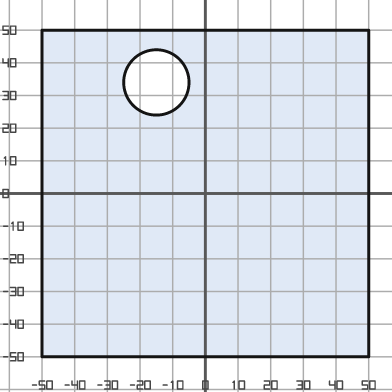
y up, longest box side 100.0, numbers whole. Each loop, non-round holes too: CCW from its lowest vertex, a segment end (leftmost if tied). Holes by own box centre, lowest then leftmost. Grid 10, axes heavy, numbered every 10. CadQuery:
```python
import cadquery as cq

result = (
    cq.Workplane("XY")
    .moveTo(-50.0, -50.0)
    .lineTo(50.0, -50.0)
    .lineTo(50.0, 50.0)
    .lineTo(-50.0, 50.0)
    .close()
    .moveTo(-15.0, 34.0)
    .circle(10.0)
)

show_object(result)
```